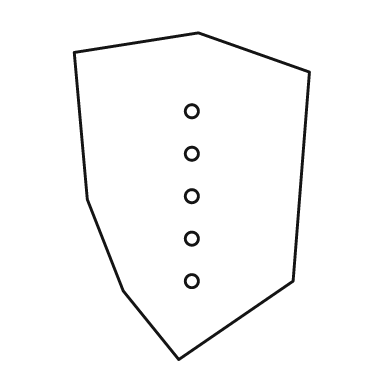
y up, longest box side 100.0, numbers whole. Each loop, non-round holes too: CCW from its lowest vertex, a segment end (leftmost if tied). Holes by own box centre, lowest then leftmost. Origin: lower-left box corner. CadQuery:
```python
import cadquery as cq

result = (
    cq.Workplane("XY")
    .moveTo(32.0, 0.0)
    .lineTo(67.0, 24.0)
    .lineTo(72.0, 88.0)
    .lineTo(38.0, 100.0)
    .lineTo(0.0, 94.0)
    .lineTo(4.0, 49.0)
    .lineTo(15.0, 21.0)
    .close()
    .moveTo(36.0, 24.0)
    .circle(2.0)
    .moveTo(36.0, 37.0)
    .circle(2.0)
    .moveTo(36.0, 50.0)
    .circle(2.0)
    .moveTo(36.0, 63.0)
    .circle(2.0)
    .moveTo(36.0, 76.0)
    .circle(2.0)
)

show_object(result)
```